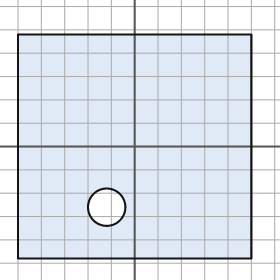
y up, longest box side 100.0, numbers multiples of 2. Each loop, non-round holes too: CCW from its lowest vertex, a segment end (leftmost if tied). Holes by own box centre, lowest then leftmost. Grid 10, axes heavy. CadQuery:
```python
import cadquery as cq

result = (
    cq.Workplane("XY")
    .moveTo(-50.0, -48.0)
    .lineTo(50.0, -48.0)
    .lineTo(50.0, 48.0)
    .lineTo(-50.0, 48.0)
    .close()
    .moveTo(-12.0, -26.0)
    .circle(8.0)
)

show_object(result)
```